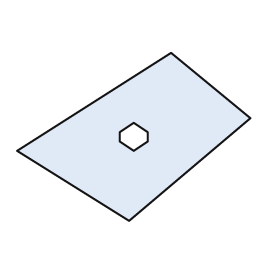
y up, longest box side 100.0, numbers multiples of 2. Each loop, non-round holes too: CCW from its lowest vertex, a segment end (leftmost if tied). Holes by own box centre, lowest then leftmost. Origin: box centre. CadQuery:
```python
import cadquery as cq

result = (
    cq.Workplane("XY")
    .moveTo(-2.0, -36.0)
    .lineTo(50.0, 8.0)
    .lineTo(16.0, 36.0)
    .lineTo(-50.0, -6.0)
    .close()
    .moveTo(0.0, -6.0)
    .lineTo(6.0, -2.0)
    .lineTo(6.0, 2.0)
    .lineTo(0.0, 6.0)
    .lineTo(-6.0, 2.0)
    .lineTo(-6.0, -2.0)
    .close()
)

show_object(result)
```